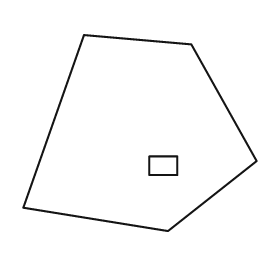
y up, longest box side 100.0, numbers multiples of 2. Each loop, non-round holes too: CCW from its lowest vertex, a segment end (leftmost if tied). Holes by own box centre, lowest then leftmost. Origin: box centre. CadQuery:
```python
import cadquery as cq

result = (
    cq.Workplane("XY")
    .moveTo(12.0, -42.0)
    .lineTo(50.0, -12.0)
    .lineTo(22.0, 38.0)
    .lineTo(-24.0, 42.0)
    .lineTo(-50.0, -32.0)
    .close()
    .moveTo(4.0, -18.0)
    .lineTo(16.0, -18.0)
    .lineTo(16.0, -10.0)
    .lineTo(4.0, -10.0)
    .close()
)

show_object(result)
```